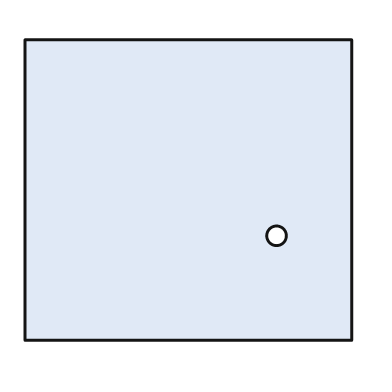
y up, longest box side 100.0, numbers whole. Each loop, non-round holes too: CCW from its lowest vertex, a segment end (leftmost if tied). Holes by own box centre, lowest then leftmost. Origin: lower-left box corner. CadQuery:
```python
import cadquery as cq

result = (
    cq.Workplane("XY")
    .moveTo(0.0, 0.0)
    .lineTo(100.0, 0.0)
    .lineTo(100.0, 92.0)
    .lineTo(0.0, 92.0)
    .close()
    .moveTo(77.0, 32.0)
    .circle(3.0)
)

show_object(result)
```